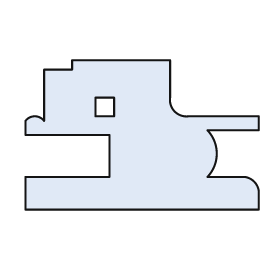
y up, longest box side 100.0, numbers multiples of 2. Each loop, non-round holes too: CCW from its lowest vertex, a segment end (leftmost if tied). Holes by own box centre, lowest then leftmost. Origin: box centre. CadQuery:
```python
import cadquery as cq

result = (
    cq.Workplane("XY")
    .moveTo(-50.0, -32.0)
    .lineTo(50.0, -32.0)
    .lineTo(50.0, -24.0)
    .threePointArc((48.0, -20.0), (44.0, -18.0))
    .lineTo(28.0, -18.0)
    .threePointArc((32.0, -8.0), (28.0, 2.0))
    .lineTo(50.0, 2.0)
    .lineTo(50.0, 8.0)
    .lineTo(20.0, 8.0)
    .threePointArc((14.0, 10.0), (12.0, 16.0))
    .lineTo(12.0, 32.0)
    .lineTo(-30.0, 32.0)
    .lineTo(-30.0, 28.0)
    .lineTo(-42.0, 28.0)
    .lineTo(-42.0, 6.0)
    .threePointArc((-46.0, 8.0), (-50.0, 6.0))
    .lineTo(-50.0, 0.0)
    .lineTo(-14.0, 0.0)
    .lineTo(-14.0, -18.0)
    .lineTo(-50.0, -18.0)
    .close()
    .moveTo(-20.0, 8.0)
    .lineTo(-12.0, 8.0)
    .lineTo(-12.0, 16.0)
    .lineTo(-20.0, 16.0)
    .close()
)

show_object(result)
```